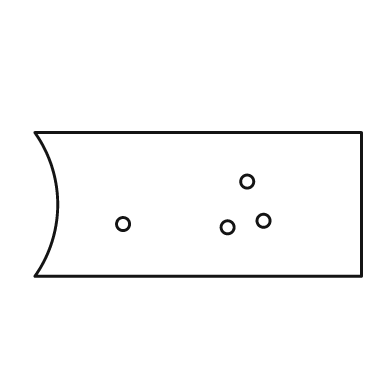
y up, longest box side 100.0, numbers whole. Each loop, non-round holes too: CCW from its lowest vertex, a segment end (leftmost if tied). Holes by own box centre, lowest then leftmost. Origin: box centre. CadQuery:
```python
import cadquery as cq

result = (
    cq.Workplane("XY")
    .moveTo(-50.0, -22.0)
    .lineTo(50.0, -22.0)
    .lineTo(50.0, 22.0)
    .lineTo(-50.0, 22.0)
    .threePointArc((-43.0, 0.0), (-50.0, -22.0))
    .close()
    .moveTo(9.0, -7.0)
    .circle(2.0)
    .moveTo(-23.0, -6.0)
    .circle(2.0)
    .moveTo(20.0, -5.0)
    .circle(2.0)
    .moveTo(15.0, 7.0)
    .circle(2.0)
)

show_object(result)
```